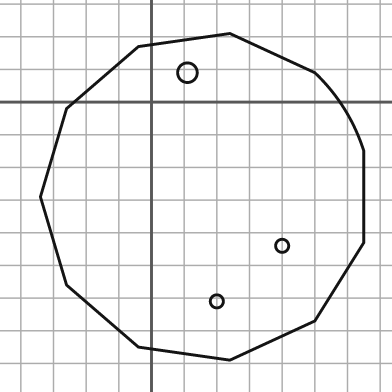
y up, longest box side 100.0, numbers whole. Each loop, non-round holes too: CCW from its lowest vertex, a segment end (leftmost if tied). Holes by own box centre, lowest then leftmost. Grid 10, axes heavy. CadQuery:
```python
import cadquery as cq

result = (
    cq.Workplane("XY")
    .moveTo(24.0, -79.0)
    .lineTo(50.0, -67.0)
    .lineTo(65.0, -43.0)
    .lineTo(65.0, -15.0)
    .threePointArc((59.0, -2.0), (50.0, 9.0))
    .lineTo(24.0, 21.0)
    .lineTo(-4.0, 17.0)
    .lineTo(-26.0, -2.0)
    .lineTo(-34.0, -29.0)
    .lineTo(-26.0, -56.0)
    .lineTo(-4.0, -75.0)
    .close()
    .moveTo(20.0, -61.0)
    .circle(2.0)
    .moveTo(40.0, -44.0)
    .circle(2.0)
    .moveTo(11.0, 9.0)
    .circle(3.0)
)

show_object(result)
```